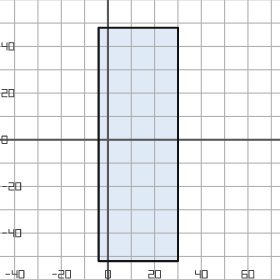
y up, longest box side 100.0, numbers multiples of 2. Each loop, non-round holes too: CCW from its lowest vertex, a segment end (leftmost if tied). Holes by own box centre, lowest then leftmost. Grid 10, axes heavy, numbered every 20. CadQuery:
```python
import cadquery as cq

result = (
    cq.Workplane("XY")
    .moveTo(-4.0, -52.0)
    .lineTo(30.0, -52.0)
    .lineTo(30.0, 48.0)
    .lineTo(-4.0, 48.0)
    .close()
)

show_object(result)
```